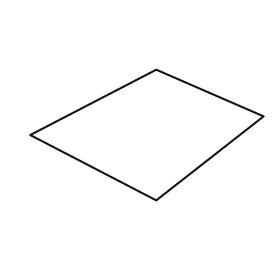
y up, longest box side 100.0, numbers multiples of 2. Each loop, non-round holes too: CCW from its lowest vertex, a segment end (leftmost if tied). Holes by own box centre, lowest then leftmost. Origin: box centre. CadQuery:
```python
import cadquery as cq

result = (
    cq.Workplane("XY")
    .moveTo(4.0, -28.0)
    .lineTo(50.0, 8.0)
    .lineTo(4.0, 28.0)
    .lineTo(-50.0, 0.0)
    .close()
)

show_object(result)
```